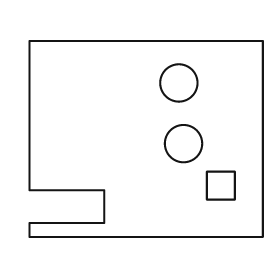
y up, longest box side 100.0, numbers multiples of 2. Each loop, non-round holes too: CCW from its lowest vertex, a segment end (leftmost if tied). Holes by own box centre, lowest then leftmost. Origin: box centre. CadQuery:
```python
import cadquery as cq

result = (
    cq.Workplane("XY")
    .moveTo(-50.0, -42.0)
    .lineTo(50.0, -42.0)
    .lineTo(50.0, 42.0)
    .lineTo(-50.0, 42.0)
    .lineTo(-50.0, -22.0)
    .lineTo(-18.0, -22.0)
    .lineTo(-18.0, -36.0)
    .lineTo(-50.0, -36.0)
    .close()
    .moveTo(26.0, -26.0)
    .lineTo(38.0, -26.0)
    .lineTo(38.0, -14.0)
    .lineTo(26.0, -14.0)
    .close()
    .moveTo(16.0, -2.0)
    .circle(8.0)
    .moveTo(14.0, 24.0)
    .circle(8.0)
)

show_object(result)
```